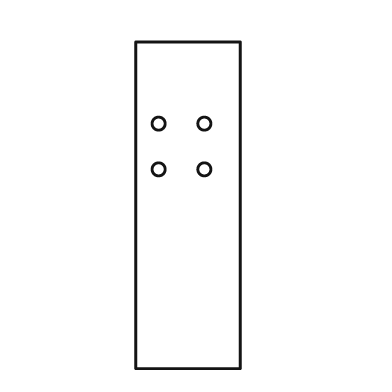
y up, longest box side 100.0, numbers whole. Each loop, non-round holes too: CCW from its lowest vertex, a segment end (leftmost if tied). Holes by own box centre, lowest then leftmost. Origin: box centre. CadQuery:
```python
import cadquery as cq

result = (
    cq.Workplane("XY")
    .moveTo(-16.0, -50.0)
    .lineTo(16.0, -50.0)
    .lineTo(16.0, 50.0)
    .lineTo(-16.0, 50.0)
    .close()
    .moveTo(-9.0, 11.0)
    .circle(2.0)
    .moveTo(5.0, 11.0)
    .circle(2.0)
    .moveTo(-9.0, 25.0)
    .circle(2.0)
    .moveTo(5.0, 25.0)
    .circle(2.0)
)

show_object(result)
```